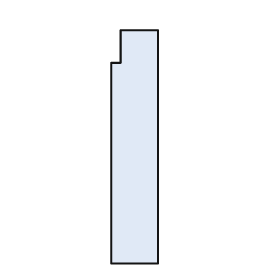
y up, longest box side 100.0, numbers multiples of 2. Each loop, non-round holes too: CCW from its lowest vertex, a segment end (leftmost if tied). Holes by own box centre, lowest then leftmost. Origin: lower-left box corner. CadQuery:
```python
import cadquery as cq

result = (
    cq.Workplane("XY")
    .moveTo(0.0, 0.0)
    .lineTo(20.0, 0.0)
    .lineTo(20.0, 100.0)
    .lineTo(4.0, 100.0)
    .lineTo(4.0, 86.0)
    .lineTo(0.0, 86.0)
    .close()
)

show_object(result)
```